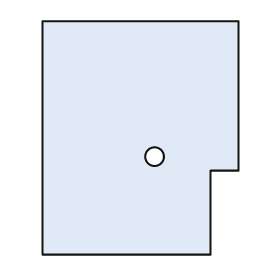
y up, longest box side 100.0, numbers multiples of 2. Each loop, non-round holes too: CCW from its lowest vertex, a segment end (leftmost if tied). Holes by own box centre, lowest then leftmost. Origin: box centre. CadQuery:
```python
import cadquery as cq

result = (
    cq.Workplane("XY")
    .moveTo(-42.0, -50.0)
    .lineTo(30.0, -50.0)
    .lineTo(30.0, -14.0)
    .lineTo(42.0, -14.0)
    .lineTo(42.0, 50.0)
    .lineTo(-42.0, 50.0)
    .close()
    .moveTo(6.0, -8.0)
    .circle(4.0)
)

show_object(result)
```